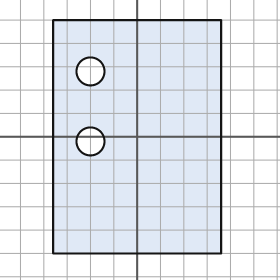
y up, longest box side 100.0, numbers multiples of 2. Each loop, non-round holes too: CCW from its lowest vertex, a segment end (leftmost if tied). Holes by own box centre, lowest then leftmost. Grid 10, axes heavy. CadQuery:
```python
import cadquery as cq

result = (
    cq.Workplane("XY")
    .moveTo(-36.0, -50.0)
    .lineTo(36.0, -50.0)
    .lineTo(36.0, 50.0)
    .lineTo(-36.0, 50.0)
    .close()
    .moveTo(-20.0, -2.0)
    .circle(6.0)
    .moveTo(-20.0, 28.0)
    .circle(6.0)
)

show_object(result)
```